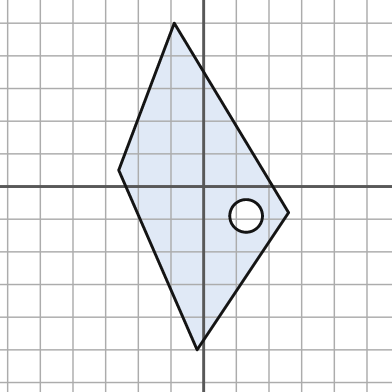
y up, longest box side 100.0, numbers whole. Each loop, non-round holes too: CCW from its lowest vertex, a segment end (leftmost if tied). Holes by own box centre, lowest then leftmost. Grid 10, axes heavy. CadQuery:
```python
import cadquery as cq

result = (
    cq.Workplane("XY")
    .moveTo(-2.0, -50.0)
    .lineTo(26.0, -8.0)
    .lineTo(-9.0, 50.0)
    .lineTo(-26.0, 5.0)
    .close()
    .moveTo(13.0, -9.0)
    .circle(5.0)
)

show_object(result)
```